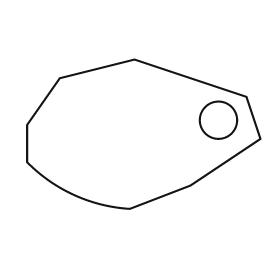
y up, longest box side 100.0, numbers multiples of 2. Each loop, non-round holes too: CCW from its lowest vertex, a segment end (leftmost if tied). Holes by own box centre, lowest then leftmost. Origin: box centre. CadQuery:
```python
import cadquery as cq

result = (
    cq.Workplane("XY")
    .moveTo(-6.0, -32.0)
    .lineTo(20.0, -22.0)
    .lineTo(50.0, -2.0)
    .lineTo(44.0, 16.0)
    .lineTo(-4.0, 32.0)
    .lineTo(-36.0, 24.0)
    .lineTo(-50.0, 4.0)
    .lineTo(-50.0, -12.0)
    .threePointArc((-30.0, -26.0), (-6.0, -32.0))
    .close()
    .moveTo(32.0, 6.0)
    .circle(8.0)
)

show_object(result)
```